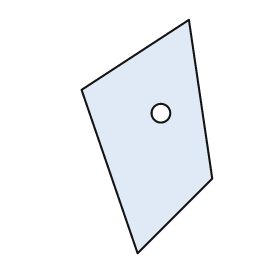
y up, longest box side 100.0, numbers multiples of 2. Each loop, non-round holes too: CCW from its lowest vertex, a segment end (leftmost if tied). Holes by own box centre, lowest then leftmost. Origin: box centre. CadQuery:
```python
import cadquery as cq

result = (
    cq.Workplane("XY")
    .moveTo(-4.0, -50.0)
    .lineTo(28.0, -18.0)
    .lineTo(18.0, 50.0)
    .lineTo(-28.0, 20.0)
    .close()
    .moveTo(6.0, 10.0)
    .circle(4.0)
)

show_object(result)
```